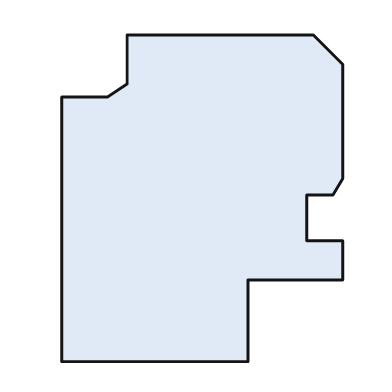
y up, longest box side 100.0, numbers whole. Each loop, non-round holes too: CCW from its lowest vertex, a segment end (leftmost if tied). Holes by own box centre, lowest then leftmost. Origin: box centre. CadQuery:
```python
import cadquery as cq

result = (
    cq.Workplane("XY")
    .moveTo(-43.0, -50.0)
    .lineTo(14.0, -50.0)
    .lineTo(14.0, -25.0)
    .lineTo(43.0, -25.0)
    .lineTo(43.0, -13.0)
    .lineTo(32.0, -13.0)
    .lineTo(32.0, 1.0)
    .lineTo(40.0, 1.0)
    .lineTo(43.0, 6.0)
    .lineTo(43.0, 41.0)
    .lineTo(34.0, 50.0)
    .lineTo(-23.0, 50.0)
    .lineTo(-23.0, 35.0)
    .lineTo(-29.0, 31.0)
    .lineTo(-43.0, 31.0)
    .close()
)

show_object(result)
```